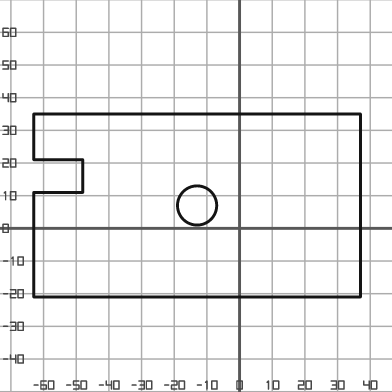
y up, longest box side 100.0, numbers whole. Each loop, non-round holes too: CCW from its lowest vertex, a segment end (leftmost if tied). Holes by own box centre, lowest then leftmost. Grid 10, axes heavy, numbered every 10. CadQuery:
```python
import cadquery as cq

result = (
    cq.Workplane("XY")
    .moveTo(-63.0, -21.0)
    .lineTo(37.0, -21.0)
    .lineTo(37.0, 35.0)
    .lineTo(-63.0, 35.0)
    .lineTo(-63.0, 21.0)
    .lineTo(-48.0, 21.0)
    .lineTo(-48.0, 11.0)
    .lineTo(-63.0, 11.0)
    .close()
    .moveTo(-13.0, 7.0)
    .circle(6.0)
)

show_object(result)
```